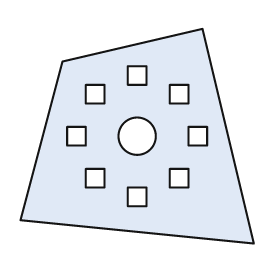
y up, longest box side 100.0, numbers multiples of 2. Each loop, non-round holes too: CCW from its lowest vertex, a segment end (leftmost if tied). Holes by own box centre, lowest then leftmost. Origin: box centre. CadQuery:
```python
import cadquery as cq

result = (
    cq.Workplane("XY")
    .moveTo(50.0, -46.0)
    .lineTo(28.0, 46.0)
    .lineTo(-32.0, 32.0)
    .lineTo(-50.0, -36.0)
    .close()
    .moveTo(-4.0, -30.0)
    .lineTo(4.0, -30.0)
    .lineTo(4.0, -22.0)
    .lineTo(-4.0, -22.0)
    .close()
    .moveTo(-22.0, -22.0)
    .lineTo(-14.0, -22.0)
    .lineTo(-14.0, -14.0)
    .lineTo(-22.0, -14.0)
    .close()
    .moveTo(14.0, -22.0)
    .lineTo(22.0, -22.0)
    .lineTo(22.0, -14.0)
    .lineTo(14.0, -14.0)
    .close()
    .moveTo(-30.0, -4.0)
    .lineTo(-22.0, -4.0)
    .lineTo(-22.0, 4.0)
    .lineTo(-30.0, 4.0)
    .close()
    .moveTo(0.0, 0.0)
    .circle(8.0)
    .moveTo(22.0, -4.0)
    .lineTo(30.0, -4.0)
    .lineTo(30.0, 4.0)
    .lineTo(22.0, 4.0)
    .close()
    .moveTo(-22.0, 14.0)
    .lineTo(-14.0, 14.0)
    .lineTo(-14.0, 22.0)
    .lineTo(-22.0, 22.0)
    .close()
    .moveTo(14.0, 14.0)
    .lineTo(22.0, 14.0)
    .lineTo(22.0, 22.0)
    .lineTo(14.0, 22.0)
    .close()
    .moveTo(-4.0, 22.0)
    .lineTo(4.0, 22.0)
    .lineTo(4.0, 30.0)
    .lineTo(-4.0, 30.0)
    .close()
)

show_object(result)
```